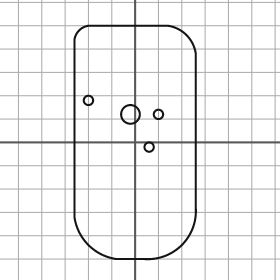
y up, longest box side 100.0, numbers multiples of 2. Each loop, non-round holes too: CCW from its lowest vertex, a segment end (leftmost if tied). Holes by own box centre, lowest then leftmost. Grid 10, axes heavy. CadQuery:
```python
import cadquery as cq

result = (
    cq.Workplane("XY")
    .moveTo(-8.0, -50.0)
    .lineTo(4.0, -50.0)
    .threePointArc((20.0, -44.0), (26.0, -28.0))
    .lineTo(26.0, 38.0)
    .threePointArc((22.0, 46.0), (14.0, 50.0))
    .lineTo(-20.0, 50.0)
    .threePointArc((-24.0, 48.0), (-26.0, 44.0))
    .lineTo(-26.0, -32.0)
    .threePointArc((-20.0, -44.0), (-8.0, -50.0))
    .close()
    .moveTo(6.0, -2.0)
    .circle(2.0)
    .moveTo(-2.0, 12.0)
    .circle(4.0)
    .moveTo(10.0, 12.0)
    .circle(2.0)
    .moveTo(-20.0, 18.0)
    .circle(2.0)
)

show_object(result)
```